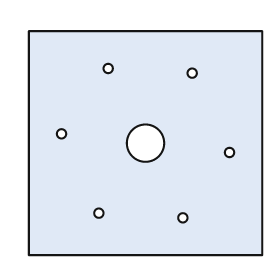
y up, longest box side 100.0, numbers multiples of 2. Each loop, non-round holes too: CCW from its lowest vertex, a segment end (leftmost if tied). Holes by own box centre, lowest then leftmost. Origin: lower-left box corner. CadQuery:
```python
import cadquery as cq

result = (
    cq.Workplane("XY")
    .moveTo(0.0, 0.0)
    .lineTo(100.0, 0.0)
    .lineTo(100.0, 96.0)
    .lineTo(0.0, 96.0)
    .close()
    .moveTo(66.0, 16.0)
    .circle(2.0)
    .moveTo(30.0, 18.0)
    .circle(2.0)
    .moveTo(86.0, 44.0)
    .circle(2.0)
    .moveTo(50.0, 48.0)
    .circle(8.0)
    .moveTo(14.0, 52.0)
    .circle(2.0)
    .moveTo(70.0, 78.0)
    .circle(2.0)
    .moveTo(34.0, 80.0)
    .circle(2.0)
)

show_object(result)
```